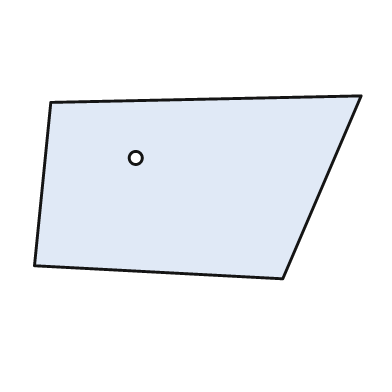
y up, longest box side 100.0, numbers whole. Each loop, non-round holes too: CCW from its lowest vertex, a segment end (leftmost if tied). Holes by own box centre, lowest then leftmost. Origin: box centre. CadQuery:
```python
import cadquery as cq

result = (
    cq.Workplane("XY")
    .moveTo(26.0, -28.0)
    .lineTo(50.0, 28.0)
    .lineTo(-45.0, 26.0)
    .lineTo(-50.0, -24.0)
    .close()
    .moveTo(-19.0, 9.0)
    .circle(2.0)
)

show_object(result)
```